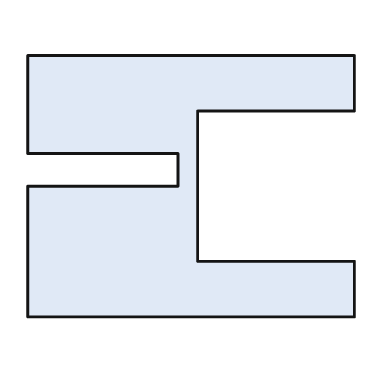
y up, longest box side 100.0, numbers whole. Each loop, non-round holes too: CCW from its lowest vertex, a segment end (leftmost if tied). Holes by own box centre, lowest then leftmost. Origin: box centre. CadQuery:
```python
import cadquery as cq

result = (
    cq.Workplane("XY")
    .moveTo(-50.0, -40.0)
    .lineTo(50.0, -40.0)
    .lineTo(50.0, -23.0)
    .lineTo(2.0, -23.0)
    .lineTo(2.0, 23.0)
    .lineTo(50.0, 23.0)
    .lineTo(50.0, 40.0)
    .lineTo(-50.0, 40.0)
    .lineTo(-50.0, 10.0)
    .lineTo(-4.0, 10.0)
    .lineTo(-4.0, 0.0)
    .lineTo(-50.0, 0.0)
    .close()
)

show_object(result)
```